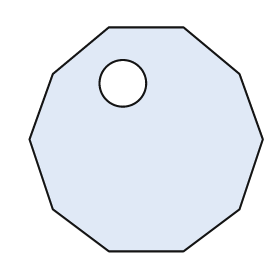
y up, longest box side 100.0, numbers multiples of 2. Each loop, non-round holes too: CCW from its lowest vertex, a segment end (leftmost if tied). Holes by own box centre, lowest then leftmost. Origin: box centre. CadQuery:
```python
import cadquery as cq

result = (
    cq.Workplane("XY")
    .moveTo(-16.0, -48.0)
    .lineTo(16.0, -48.0)
    .lineTo(40.0, -30.0)
    .lineTo(50.0, 0.0)
    .lineTo(40.0, 28.0)
    .lineTo(16.0, 48.0)
    .lineTo(-16.0, 48.0)
    .lineTo(-40.0, 28.0)
    .lineTo(-50.0, 0.0)
    .lineTo(-40.0, -30.0)
    .close()
    .moveTo(-10.0, 24.0)
    .circle(10.0)
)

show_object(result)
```